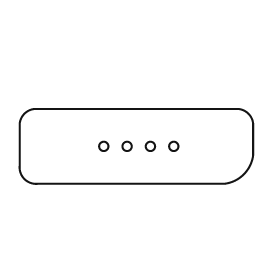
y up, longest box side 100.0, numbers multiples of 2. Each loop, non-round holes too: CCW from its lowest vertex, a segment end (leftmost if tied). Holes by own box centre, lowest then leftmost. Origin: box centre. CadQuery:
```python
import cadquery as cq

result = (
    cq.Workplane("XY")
    .moveTo(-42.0, -16.0)
    .lineTo(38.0, -16.0)
    .threePointArc((46.0, -12.0), (50.0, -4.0))
    .lineTo(50.0, 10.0)
    .threePointArc((48.0, 14.0), (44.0, 16.0))
    .lineTo(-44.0, 16.0)
    .threePointArc((-48.0, 14.0), (-50.0, 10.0))
    .lineTo(-50.0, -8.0)
    .threePointArc((-48.0, -14.0), (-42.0, -16.0))
    .close()
    .moveTo(-14.0, 0.0)
    .circle(2.0)
    .moveTo(-4.0, 0.0)
    .circle(2.0)
    .moveTo(6.0, 0.0)
    .circle(2.0)
    .moveTo(16.0, 0.0)
    .circle(2.0)
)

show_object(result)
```